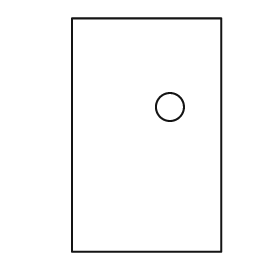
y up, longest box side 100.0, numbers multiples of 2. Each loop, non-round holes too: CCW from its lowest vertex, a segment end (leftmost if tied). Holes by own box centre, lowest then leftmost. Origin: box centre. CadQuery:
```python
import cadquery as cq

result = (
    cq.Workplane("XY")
    .moveTo(-32.0, -50.0)
    .lineTo(32.0, -50.0)
    .lineTo(32.0, 50.0)
    .lineTo(-32.0, 50.0)
    .close()
    .moveTo(10.0, 12.0)
    .circle(6.0)
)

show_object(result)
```